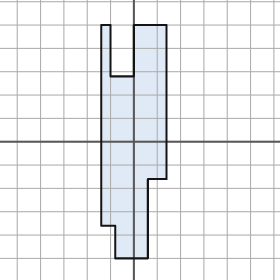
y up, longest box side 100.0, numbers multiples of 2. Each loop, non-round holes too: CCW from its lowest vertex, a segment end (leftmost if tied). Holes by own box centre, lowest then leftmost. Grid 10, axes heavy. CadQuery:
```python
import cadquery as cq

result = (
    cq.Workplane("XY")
    .moveTo(-8.0, -50.0)
    .lineTo(6.0, -50.0)
    .lineTo(6.0, -16.0)
    .lineTo(14.0, -16.0)
    .lineTo(14.0, 50.0)
    .lineTo(0.0, 50.0)
    .lineTo(0.0, 28.0)
    .lineTo(-10.0, 28.0)
    .lineTo(-10.0, 50.0)
    .lineTo(-14.0, 50.0)
    .lineTo(-14.0, -36.0)
    .lineTo(-8.0, -36.0)
    .close()
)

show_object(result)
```